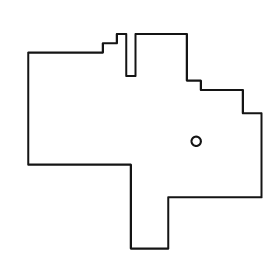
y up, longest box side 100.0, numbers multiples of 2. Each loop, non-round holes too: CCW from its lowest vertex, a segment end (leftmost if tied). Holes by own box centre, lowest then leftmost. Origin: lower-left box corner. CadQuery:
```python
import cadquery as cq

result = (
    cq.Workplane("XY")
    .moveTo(44.0, 0.0)
    .lineTo(60.0, 0.0)
    .lineTo(60.0, 22.0)
    .lineTo(100.0, 22.0)
    .lineTo(100.0, 58.0)
    .lineTo(92.0, 58.0)
    .lineTo(92.0, 68.0)
    .lineTo(74.0, 68.0)
    .lineTo(74.0, 72.0)
    .lineTo(68.0, 72.0)
    .lineTo(68.0, 92.0)
    .lineTo(46.0, 92.0)
    .lineTo(46.0, 74.0)
    .lineTo(42.0, 74.0)
    .lineTo(42.0, 92.0)
    .lineTo(38.0, 92.0)
    .lineTo(38.0, 88.0)
    .lineTo(32.0, 88.0)
    .lineTo(32.0, 84.0)
    .lineTo(0.0, 84.0)
    .lineTo(0.0, 36.0)
    .lineTo(44.0, 36.0)
    .close()
    .moveTo(72.0, 46.0)
    .circle(2.0)
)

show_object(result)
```